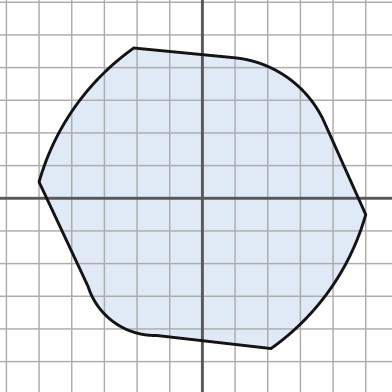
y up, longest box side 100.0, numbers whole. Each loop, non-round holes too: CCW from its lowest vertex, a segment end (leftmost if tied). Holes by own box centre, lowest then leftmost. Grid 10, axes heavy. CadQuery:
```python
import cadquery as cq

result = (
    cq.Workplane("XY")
    .moveTo(21.0, -46.0)
    .threePointArc((39.0, -28.0), (50.0, -5.0))
    .lineTo(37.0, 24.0)
    .threePointArc((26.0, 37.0), (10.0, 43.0))
    .lineTo(-21.0, 46.0)
    .threePointArc((-39.0, 28.0), (-50.0, 5.0))
    .lineTo(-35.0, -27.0)
    .threePointArc((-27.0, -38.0), (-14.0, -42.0))
    .close()
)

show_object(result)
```